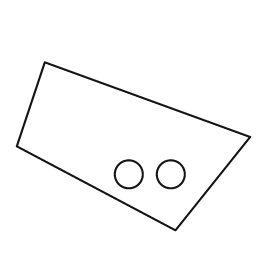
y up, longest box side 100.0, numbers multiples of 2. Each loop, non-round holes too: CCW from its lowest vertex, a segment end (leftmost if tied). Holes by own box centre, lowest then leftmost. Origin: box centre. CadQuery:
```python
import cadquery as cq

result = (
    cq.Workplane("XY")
    .moveTo(18.0, -36.0)
    .lineTo(50.0, 4.0)
    .lineTo(-38.0, 36.0)
    .lineTo(-50.0, 0.0)
    .close()
    .moveTo(-2.0, -12.0)
    .circle(6.0)
    .moveTo(16.0, -12.0)
    .circle(6.0)
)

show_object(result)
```